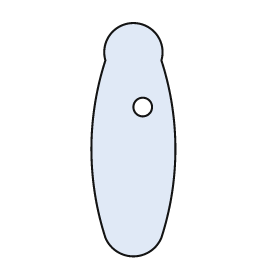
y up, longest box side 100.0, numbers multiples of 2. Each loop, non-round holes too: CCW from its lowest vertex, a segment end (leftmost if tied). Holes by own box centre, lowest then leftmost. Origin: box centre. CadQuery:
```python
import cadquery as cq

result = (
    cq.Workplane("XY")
    .moveTo(-12.0, -42.0)
    .threePointArc((0.0, -50.0), (12.0, -42.0))
    .threePointArc((18.0, -4.0), (12.0, 34.0))
    .threePointArc((0.0, 50.0), (-12.0, 34.0))
    .threePointArc((-18.0, -4.0), (-12.0, -42.0))
    .close()
    .moveTo(4.0, 14.0)
    .circle(4.0)
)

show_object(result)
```